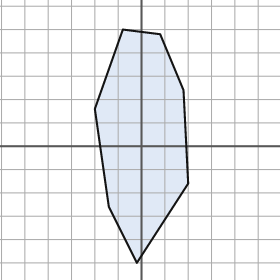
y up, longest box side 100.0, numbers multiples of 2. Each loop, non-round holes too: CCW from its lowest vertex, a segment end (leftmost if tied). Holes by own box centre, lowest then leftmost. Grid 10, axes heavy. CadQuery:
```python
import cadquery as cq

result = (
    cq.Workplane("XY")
    .moveTo(-2.0, -50.0)
    .lineTo(20.0, -16.0)
    .lineTo(18.0, 24.0)
    .lineTo(8.0, 48.0)
    .lineTo(-8.0, 50.0)
    .lineTo(-20.0, 16.0)
    .lineTo(-14.0, -26.0)
    .close()
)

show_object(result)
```